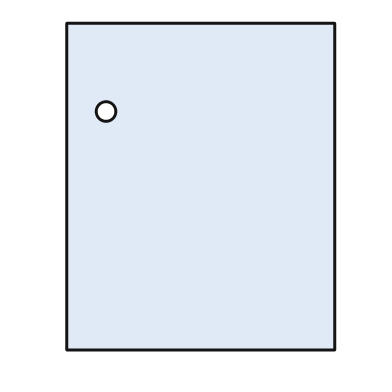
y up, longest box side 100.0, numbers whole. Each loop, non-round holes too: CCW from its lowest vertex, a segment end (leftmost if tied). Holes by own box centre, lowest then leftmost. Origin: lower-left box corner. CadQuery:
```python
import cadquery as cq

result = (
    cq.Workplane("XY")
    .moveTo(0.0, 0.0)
    .lineTo(82.0, 0.0)
    .lineTo(82.0, 100.0)
    .lineTo(0.0, 100.0)
    .close()
    .moveTo(12.0, 73.0)
    .circle(3.0)
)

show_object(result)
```